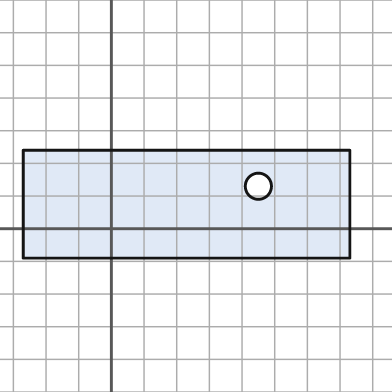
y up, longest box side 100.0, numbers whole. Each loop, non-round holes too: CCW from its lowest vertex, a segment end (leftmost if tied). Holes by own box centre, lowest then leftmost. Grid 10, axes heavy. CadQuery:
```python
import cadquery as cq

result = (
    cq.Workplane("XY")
    .moveTo(-27.0, -9.0)
    .lineTo(73.0, -9.0)
    .lineTo(73.0, 24.0)
    .lineTo(-27.0, 24.0)
    .close()
    .moveTo(45.0, 13.0)
    .circle(4.0)
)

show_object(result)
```